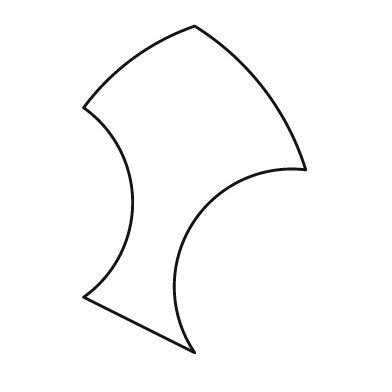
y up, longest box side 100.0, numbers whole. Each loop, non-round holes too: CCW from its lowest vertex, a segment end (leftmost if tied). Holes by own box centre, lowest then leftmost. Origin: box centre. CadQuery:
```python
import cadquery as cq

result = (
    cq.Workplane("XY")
    .moveTo(0.0, -50.0)
    .threePointArc((-1.0, -11.0), (34.0, 6.0))
    .threePointArc((21.0, 31.0), (0.0, 50.0))
    .threePointArc((-19.0, 40.0), (-34.0, 25.0))
    .threePointArc((-19.0, -4.0), (-34.0, -33.0))
    .close()
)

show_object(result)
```